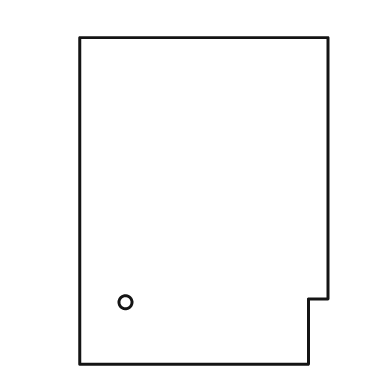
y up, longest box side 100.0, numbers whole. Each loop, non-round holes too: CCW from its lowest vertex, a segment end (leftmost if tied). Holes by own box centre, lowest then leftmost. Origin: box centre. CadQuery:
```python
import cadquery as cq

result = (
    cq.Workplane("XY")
    .moveTo(-38.0, -50.0)
    .lineTo(32.0, -50.0)
    .lineTo(32.0, -30.0)
    .lineTo(38.0, -30.0)
    .lineTo(38.0, 50.0)
    .lineTo(-38.0, 50.0)
    .close()
    .moveTo(-24.0, -31.0)
    .circle(2.0)
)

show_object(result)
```